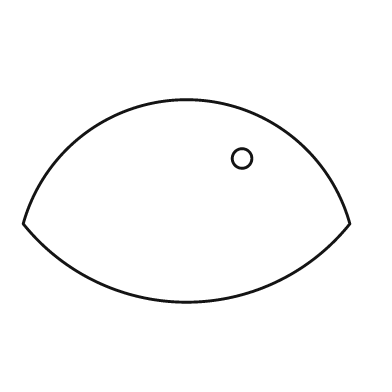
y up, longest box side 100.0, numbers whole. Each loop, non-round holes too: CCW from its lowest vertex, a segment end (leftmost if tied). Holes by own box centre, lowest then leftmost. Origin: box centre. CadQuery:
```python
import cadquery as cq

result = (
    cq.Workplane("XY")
    .moveTo(-50.0, -7.0)
    .threePointArc((0.0, -31.0), (50.0, -7.0))
    .threePointArc((0.0, 31.0), (-50.0, -7.0))
    .close()
    .moveTo(17.0, 13.0)
    .circle(3.0)
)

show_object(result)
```